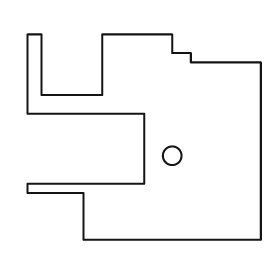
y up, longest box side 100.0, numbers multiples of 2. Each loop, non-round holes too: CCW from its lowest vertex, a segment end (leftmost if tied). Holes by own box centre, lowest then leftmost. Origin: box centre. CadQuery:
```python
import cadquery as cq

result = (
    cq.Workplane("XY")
    .moveTo(-26.0, -44.0)
    .lineTo(50.0, -44.0)
    .lineTo(50.0, 32.0)
    .lineTo(20.0, 32.0)
    .lineTo(20.0, 36.0)
    .lineTo(12.0, 36.0)
    .lineTo(12.0, 44.0)
    .lineTo(-18.0, 44.0)
    .lineTo(-18.0, 18.0)
    .lineTo(-44.0, 18.0)
    .lineTo(-44.0, 44.0)
    .lineTo(-50.0, 44.0)
    .lineTo(-50.0, 10.0)
    .lineTo(0.0, 10.0)
    .lineTo(0.0, -20.0)
    .lineTo(-50.0, -20.0)
    .lineTo(-50.0, -24.0)
    .lineTo(-26.0, -24.0)
    .close()
    .moveTo(12.0, -8.0)
    .circle(4.0)
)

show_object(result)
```